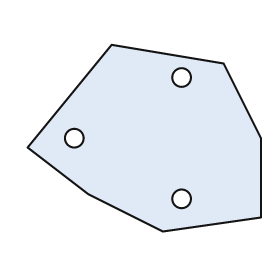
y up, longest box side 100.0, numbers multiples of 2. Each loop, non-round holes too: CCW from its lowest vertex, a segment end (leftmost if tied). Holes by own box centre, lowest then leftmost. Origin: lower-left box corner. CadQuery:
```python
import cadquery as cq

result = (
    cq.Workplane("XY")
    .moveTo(58.0, 0.0)
    .lineTo(100.0, 6.0)
    .lineTo(100.0, 40.0)
    .lineTo(84.0, 72.0)
    .lineTo(36.0, 80.0)
    .lineTo(0.0, 36.0)
    .lineTo(26.0, 16.0)
    .close()
    .moveTo(66.0, 14.0)
    .circle(4.0)
    .moveTo(20.0, 40.0)
    .circle(4.0)
    .moveTo(66.0, 66.0)
    .circle(4.0)
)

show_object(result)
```